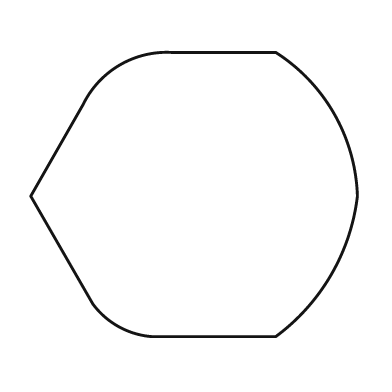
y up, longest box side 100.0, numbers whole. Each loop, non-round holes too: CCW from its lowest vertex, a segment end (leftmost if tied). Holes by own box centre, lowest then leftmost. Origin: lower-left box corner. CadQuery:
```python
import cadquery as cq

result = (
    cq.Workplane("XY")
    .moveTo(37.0, 0.0)
    .lineTo(75.0, 0.0)
    .threePointArc((92.0, 19.0), (100.0, 43.0))
    .threePointArc((93.0, 68.0), (75.0, 87.0))
    .lineTo(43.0, 87.0)
    .threePointArc((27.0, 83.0), (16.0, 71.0))
    .lineTo(0.0, 43.0)
    .lineTo(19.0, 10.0)
    .threePointArc((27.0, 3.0), (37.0, 0.0))
    .close()
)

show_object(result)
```